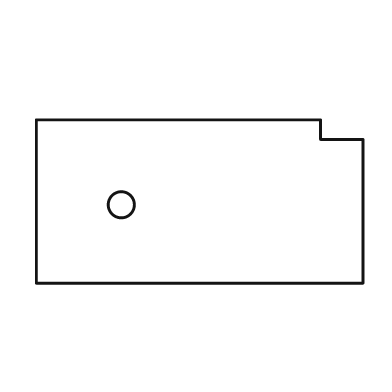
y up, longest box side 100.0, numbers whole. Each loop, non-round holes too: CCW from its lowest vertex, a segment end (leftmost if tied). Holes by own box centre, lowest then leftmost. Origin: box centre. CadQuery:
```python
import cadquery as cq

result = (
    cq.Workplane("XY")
    .moveTo(-50.0, -25.0)
    .lineTo(50.0, -25.0)
    .lineTo(50.0, 19.0)
    .lineTo(37.0, 19.0)
    .lineTo(37.0, 25.0)
    .lineTo(-50.0, 25.0)
    .close()
    .moveTo(-24.0, -1.0)
    .circle(4.0)
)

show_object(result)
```